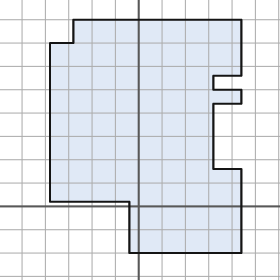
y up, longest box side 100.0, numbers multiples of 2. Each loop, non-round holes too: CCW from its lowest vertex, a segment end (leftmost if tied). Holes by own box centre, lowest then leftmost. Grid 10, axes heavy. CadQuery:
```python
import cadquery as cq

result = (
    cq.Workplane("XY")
    .moveTo(-4.0, -20.0)
    .lineTo(44.0, -20.0)
    .lineTo(44.0, 16.0)
    .lineTo(32.0, 16.0)
    .lineTo(32.0, 44.0)
    .lineTo(44.0, 44.0)
    .lineTo(44.0, 50.0)
    .lineTo(32.0, 50.0)
    .lineTo(32.0, 56.0)
    .lineTo(44.0, 56.0)
    .lineTo(44.0, 80.0)
    .lineTo(-28.0, 80.0)
    .lineTo(-28.0, 70.0)
    .lineTo(-38.0, 70.0)
    .lineTo(-38.0, 2.0)
    .lineTo(-4.0, 2.0)
    .close()
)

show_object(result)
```